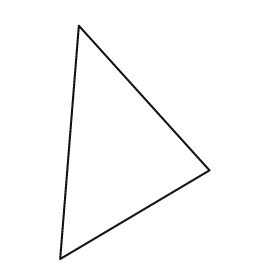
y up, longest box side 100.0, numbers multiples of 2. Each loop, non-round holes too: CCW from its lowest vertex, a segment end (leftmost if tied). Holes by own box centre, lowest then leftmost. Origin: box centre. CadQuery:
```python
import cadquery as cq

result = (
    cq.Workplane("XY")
    .moveTo(-32.0, -50.0)
    .lineTo(32.0, -12.0)
    .lineTo(-24.0, 50.0)
    .close()
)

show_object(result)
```